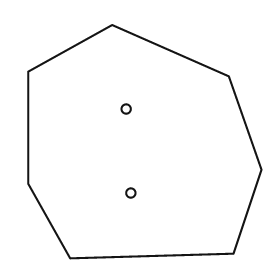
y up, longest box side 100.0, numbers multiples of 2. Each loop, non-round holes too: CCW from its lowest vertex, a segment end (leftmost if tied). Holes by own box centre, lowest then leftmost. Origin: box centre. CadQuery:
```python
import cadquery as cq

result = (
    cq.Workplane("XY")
    .moveTo(-32.0, -50.0)
    .lineTo(38.0, -48.0)
    .lineTo(50.0, -12.0)
    .lineTo(36.0, 28.0)
    .lineTo(-14.0, 50.0)
    .lineTo(-50.0, 30.0)
    .lineTo(-50.0, -18.0)
    .close()
    .moveTo(-6.0, -22.0)
    .circle(2.0)
    .moveTo(-8.0, 14.0)
    .circle(2.0)
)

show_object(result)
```